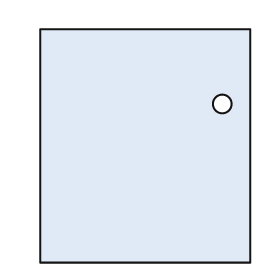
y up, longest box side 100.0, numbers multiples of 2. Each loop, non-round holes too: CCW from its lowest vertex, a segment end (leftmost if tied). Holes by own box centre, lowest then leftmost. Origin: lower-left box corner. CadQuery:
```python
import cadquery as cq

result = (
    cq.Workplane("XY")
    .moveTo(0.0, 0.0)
    .lineTo(90.0, 0.0)
    .lineTo(90.0, 100.0)
    .lineTo(0.0, 100.0)
    .close()
    .moveTo(78.0, 68.0)
    .circle(4.0)
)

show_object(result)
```